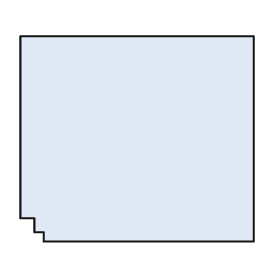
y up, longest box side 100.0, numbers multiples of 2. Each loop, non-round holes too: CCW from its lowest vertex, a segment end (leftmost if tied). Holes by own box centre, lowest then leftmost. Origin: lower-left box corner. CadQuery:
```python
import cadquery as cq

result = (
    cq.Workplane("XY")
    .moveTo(10.0, 0.0)
    .lineTo(100.0, 0.0)
    .lineTo(100.0, 88.0)
    .lineTo(0.0, 88.0)
    .lineTo(0.0, 10.0)
    .lineTo(6.0, 10.0)
    .lineTo(6.0, 4.0)
    .lineTo(10.0, 4.0)
    .close()
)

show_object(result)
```